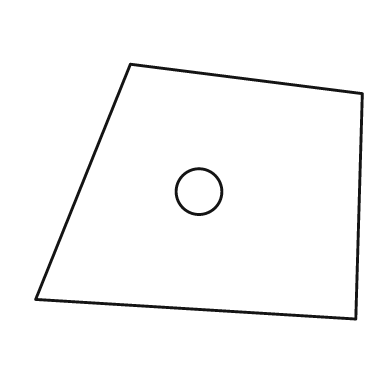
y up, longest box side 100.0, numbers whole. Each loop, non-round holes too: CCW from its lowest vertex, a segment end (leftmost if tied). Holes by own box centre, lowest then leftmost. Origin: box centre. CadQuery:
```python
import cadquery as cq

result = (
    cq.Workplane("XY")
    .moveTo(48.0, -39.0)
    .lineTo(50.0, 30.0)
    .lineTo(-21.0, 39.0)
    .lineTo(-50.0, -33.0)
    .close()
    .moveTo(0.0, 0.0)
    .circle(7.0)
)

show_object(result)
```